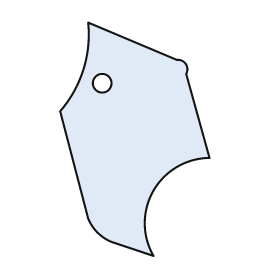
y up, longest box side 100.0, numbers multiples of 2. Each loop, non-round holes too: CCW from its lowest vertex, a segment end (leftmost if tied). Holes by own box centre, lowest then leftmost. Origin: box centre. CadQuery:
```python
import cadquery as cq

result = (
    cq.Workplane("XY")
    .moveTo(8.0, -50.0)
    .threePointArc((8.0, -22.0), (32.0, -8.0))
    .lineTo(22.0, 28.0)
    .threePointArc((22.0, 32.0), (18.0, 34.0))
    .lineTo(-20.0, 50.0)
    .threePointArc((-22.0, 30.0), (-32.0, 12.0))
    .lineTo(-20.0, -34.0)
    .threePointArc((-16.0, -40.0), (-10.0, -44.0))
    .close()
    .moveTo(-14.0, 24.0)
    .circle(4.0)
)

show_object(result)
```